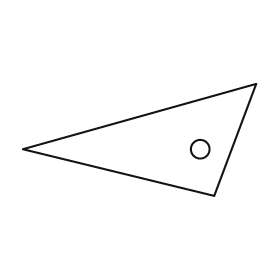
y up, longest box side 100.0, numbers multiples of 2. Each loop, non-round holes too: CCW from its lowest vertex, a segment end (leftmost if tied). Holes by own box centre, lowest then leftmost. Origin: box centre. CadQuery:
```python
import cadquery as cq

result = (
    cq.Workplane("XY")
    .moveTo(32.0, -24.0)
    .lineTo(50.0, 24.0)
    .lineTo(-50.0, -4.0)
    .close()
    .moveTo(26.0, -4.0)
    .circle(4.0)
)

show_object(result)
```